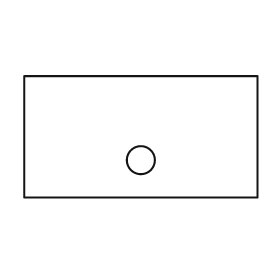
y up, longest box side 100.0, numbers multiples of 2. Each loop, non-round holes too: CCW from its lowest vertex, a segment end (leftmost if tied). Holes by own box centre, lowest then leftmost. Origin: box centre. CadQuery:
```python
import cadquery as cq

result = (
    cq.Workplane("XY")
    .moveTo(-50.0, -26.0)
    .lineTo(50.0, -26.0)
    .lineTo(50.0, 26.0)
    .lineTo(-50.0, 26.0)
    .close()
    .moveTo(0.0, -10.0)
    .circle(6.0)
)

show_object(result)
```